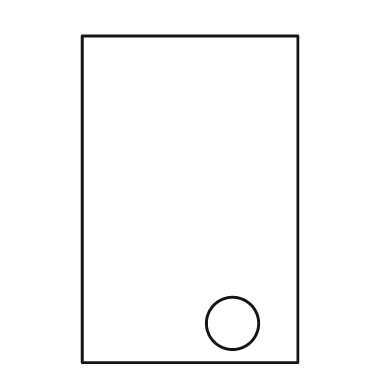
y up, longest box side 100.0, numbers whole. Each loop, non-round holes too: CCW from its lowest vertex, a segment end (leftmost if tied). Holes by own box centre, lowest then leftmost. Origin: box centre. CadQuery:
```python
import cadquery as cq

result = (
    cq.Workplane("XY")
    .moveTo(-33.0, -50.0)
    .lineTo(33.0, -50.0)
    .lineTo(33.0, 50.0)
    .lineTo(-33.0, 50.0)
    .close()
    .moveTo(13.0, -38.0)
    .circle(8.0)
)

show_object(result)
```